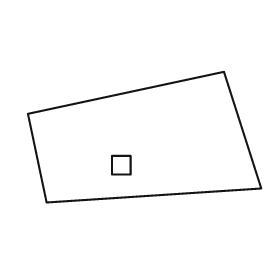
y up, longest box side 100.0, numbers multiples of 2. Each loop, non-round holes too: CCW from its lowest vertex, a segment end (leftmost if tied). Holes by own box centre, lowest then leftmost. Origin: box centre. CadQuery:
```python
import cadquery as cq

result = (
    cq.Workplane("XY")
    .moveTo(-42.0, -28.0)
    .lineTo(50.0, -22.0)
    .lineTo(34.0, 28.0)
    .lineTo(-50.0, 10.0)
    .close()
    .moveTo(-14.0, -16.0)
    .lineTo(-6.0, -16.0)
    .lineTo(-6.0, -8.0)
    .lineTo(-14.0, -8.0)
    .close()
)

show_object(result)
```